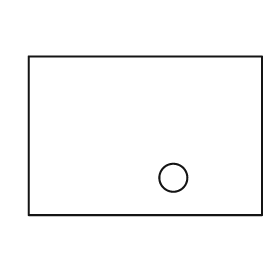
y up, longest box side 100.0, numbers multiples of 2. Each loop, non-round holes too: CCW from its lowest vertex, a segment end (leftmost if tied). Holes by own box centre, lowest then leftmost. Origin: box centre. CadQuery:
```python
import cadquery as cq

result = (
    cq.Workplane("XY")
    .moveTo(-50.0, -34.0)
    .lineTo(50.0, -34.0)
    .lineTo(50.0, 34.0)
    .lineTo(-50.0, 34.0)
    .close()
    .moveTo(12.0, -18.0)
    .circle(6.0)
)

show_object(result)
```